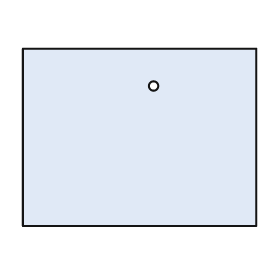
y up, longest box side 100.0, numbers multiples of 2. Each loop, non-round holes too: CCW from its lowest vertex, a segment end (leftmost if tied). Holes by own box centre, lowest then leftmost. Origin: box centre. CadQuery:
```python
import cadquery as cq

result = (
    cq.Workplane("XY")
    .moveTo(-50.0, -38.0)
    .lineTo(50.0, -38.0)
    .lineTo(50.0, 38.0)
    .lineTo(-50.0, 38.0)
    .close()
    .moveTo(6.0, 22.0)
    .circle(2.0)
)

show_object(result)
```